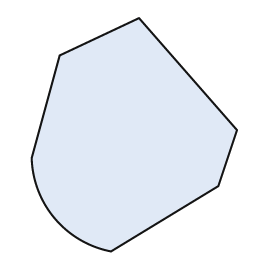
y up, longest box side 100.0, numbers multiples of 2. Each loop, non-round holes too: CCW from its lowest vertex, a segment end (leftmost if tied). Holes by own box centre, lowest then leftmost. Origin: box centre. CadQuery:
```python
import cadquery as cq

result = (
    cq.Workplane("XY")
    .moveTo(-10.0, -50.0)
    .lineTo(36.0, -22.0)
    .lineTo(44.0, 2.0)
    .lineTo(2.0, 50.0)
    .lineTo(-32.0, 34.0)
    .lineTo(-44.0, -10.0)
    .threePointArc((-34.0, -36.0), (-10.0, -50.0))
    .close()
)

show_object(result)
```